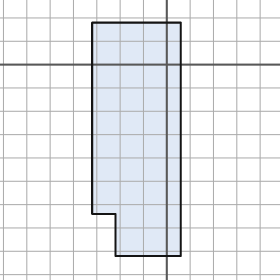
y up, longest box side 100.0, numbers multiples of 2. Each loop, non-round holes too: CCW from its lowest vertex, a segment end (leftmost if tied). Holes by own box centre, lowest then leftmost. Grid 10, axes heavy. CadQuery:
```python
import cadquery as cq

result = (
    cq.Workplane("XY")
    .moveTo(-22.0, -82.0)
    .lineTo(6.0, -82.0)
    .lineTo(6.0, 18.0)
    .lineTo(-32.0, 18.0)
    .lineTo(-32.0, -64.0)
    .lineTo(-22.0, -64.0)
    .close()
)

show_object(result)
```